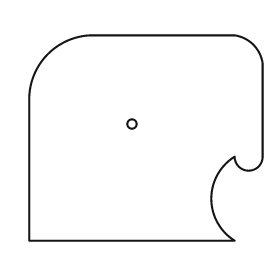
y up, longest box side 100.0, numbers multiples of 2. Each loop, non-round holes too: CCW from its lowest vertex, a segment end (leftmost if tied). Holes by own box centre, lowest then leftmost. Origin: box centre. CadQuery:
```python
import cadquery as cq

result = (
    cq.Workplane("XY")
    .moveTo(-50.0, -44.0)
    .lineTo(38.0, -44.0)
    .threePointArc((28.0, -26.0), (38.0, -8.0))
    .threePointArc((44.0, -14.0), (50.0, -8.0))
    .lineTo(50.0, 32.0)
    .threePointArc((46.0, 40.0), (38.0, 44.0))
    .lineTo(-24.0, 44.0)
    .threePointArc((-42.0, 36.0), (-50.0, 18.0))
    .close()
    .moveTo(-6.0, 6.0)
    .circle(2.0)
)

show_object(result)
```